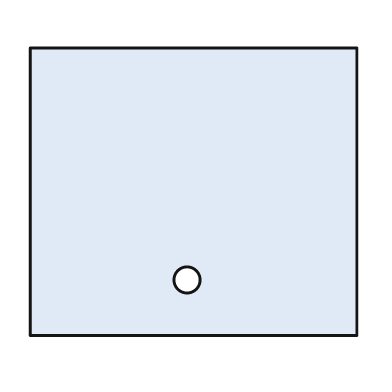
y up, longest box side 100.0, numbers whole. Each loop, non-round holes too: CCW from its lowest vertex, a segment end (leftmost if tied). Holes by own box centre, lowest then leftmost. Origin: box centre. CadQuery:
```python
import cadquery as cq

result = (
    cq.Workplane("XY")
    .moveTo(-50.0, -44.0)
    .lineTo(50.0, -44.0)
    .lineTo(50.0, 44.0)
    .lineTo(-50.0, 44.0)
    .close()
    .moveTo(-2.0, -27.0)
    .circle(4.0)
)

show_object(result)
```